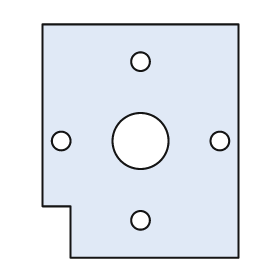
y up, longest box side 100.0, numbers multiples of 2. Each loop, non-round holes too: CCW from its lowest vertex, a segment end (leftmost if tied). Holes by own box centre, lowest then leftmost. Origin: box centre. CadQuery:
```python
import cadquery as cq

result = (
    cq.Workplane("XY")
    .moveTo(-30.0, -50.0)
    .lineTo(42.0, -50.0)
    .lineTo(42.0, 50.0)
    .lineTo(-42.0, 50.0)
    .lineTo(-42.0, -28.0)
    .lineTo(-30.0, -28.0)
    .close()
    .moveTo(0.0, -34.0)
    .circle(4.0)
    .moveTo(-34.0, 0.0)
    .circle(4.0)
    .moveTo(0.0, 0.0)
    .circle(12.0)
    .moveTo(34.0, 0.0)
    .circle(4.0)
    .moveTo(0.0, 34.0)
    .circle(4.0)
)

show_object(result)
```